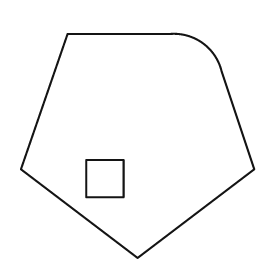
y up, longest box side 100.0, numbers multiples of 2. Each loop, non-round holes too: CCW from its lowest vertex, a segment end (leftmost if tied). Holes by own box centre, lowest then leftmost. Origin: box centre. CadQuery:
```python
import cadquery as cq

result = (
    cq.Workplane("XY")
    .moveTo(0.0, -48.0)
    .lineTo(50.0, -10.0)
    .lineTo(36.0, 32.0)
    .threePointArc((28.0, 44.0), (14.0, 48.0))
    .lineTo(-30.0, 48.0)
    .lineTo(-50.0, -10.0)
    .close()
    .moveTo(-22.0, -22.0)
    .lineTo(-6.0, -22.0)
    .lineTo(-6.0, -6.0)
    .lineTo(-22.0, -6.0)
    .close()
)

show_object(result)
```